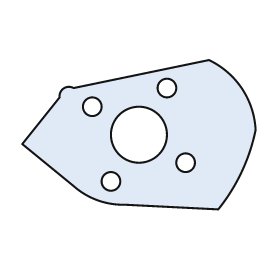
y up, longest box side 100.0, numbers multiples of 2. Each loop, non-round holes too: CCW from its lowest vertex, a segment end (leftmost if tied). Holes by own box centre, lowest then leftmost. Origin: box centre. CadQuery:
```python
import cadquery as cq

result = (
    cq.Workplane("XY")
    .moveTo(34.0, -32.0)
    .threePointArc((44.0, -16.0), (50.0, 2.0))
    .threePointArc((44.0, 20.0), (30.0, 32.0))
    .lineTo(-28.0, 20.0)
    .threePointArc((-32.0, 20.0), (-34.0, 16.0))
    .lineTo(-50.0, -4.0)
    .lineTo(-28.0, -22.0)
    .threePointArc((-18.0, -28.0), (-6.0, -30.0))
    .close()
    .moveTo(-12.0, -20.0)
    .circle(4.0)
    .moveTo(20.0, -12.0)
    .circle(4.0)
    .moveTo(0.0, 0.0)
    .circle(12.0)
    .moveTo(-20.0, 12.0)
    .circle(4.0)
    .moveTo(12.0, 20.0)
    .circle(4.0)
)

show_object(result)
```